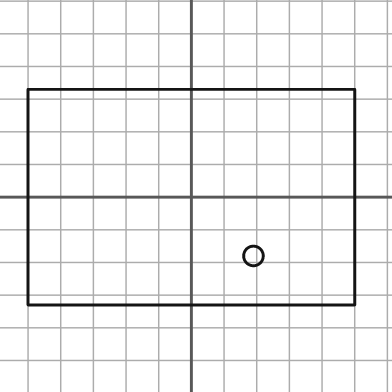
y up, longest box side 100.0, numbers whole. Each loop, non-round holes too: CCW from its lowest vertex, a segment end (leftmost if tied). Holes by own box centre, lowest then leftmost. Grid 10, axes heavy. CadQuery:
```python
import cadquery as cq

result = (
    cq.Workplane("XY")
    .moveTo(-50.0, -33.0)
    .lineTo(50.0, -33.0)
    .lineTo(50.0, 33.0)
    .lineTo(-50.0, 33.0)
    .close()
    .moveTo(19.0, -18.0)
    .circle(3.0)
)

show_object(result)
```